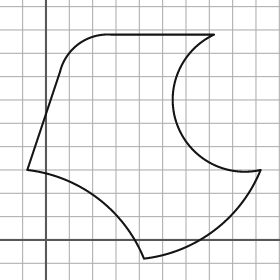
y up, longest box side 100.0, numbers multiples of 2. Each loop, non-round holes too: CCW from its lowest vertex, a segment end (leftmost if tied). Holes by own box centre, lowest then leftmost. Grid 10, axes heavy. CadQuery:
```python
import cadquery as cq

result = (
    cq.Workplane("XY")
    .moveTo(42.0, -8.0)
    .threePointArc((72.0, 4.0), (92.0, 30.0))
    .threePointArc((56.0, 50.0), (72.0, 88.0))
    .lineTo(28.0, 88.0)
    .threePointArc((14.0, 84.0), (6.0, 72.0))
    .lineTo(-8.0, 30.0)
    .threePointArc((22.0, 18.0), (42.0, -8.0))
    .close()
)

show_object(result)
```